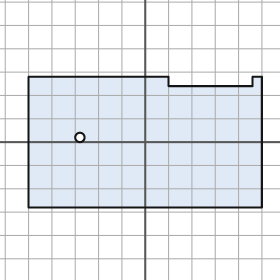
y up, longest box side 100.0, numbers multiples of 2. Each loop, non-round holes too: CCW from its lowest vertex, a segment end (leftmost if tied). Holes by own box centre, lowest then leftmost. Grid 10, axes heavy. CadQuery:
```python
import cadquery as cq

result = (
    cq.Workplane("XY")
    .moveTo(-50.0, -28.0)
    .lineTo(50.0, -28.0)
    .lineTo(50.0, 28.0)
    .lineTo(46.0, 28.0)
    .lineTo(46.0, 24.0)
    .lineTo(10.0, 24.0)
    .lineTo(10.0, 28.0)
    .lineTo(-50.0, 28.0)
    .close()
    .moveTo(-28.0, 2.0)
    .circle(2.0)
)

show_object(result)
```